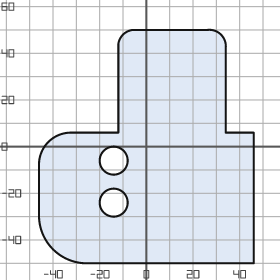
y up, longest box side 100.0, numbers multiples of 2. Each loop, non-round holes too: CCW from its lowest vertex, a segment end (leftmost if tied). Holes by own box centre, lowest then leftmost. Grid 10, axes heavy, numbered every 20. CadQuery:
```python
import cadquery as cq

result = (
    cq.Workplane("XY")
    .moveTo(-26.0, -50.0)
    .lineTo(46.0, -50.0)
    .lineTo(46.0, 6.0)
    .lineTo(34.0, 6.0)
    .lineTo(34.0, 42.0)
    .threePointArc((32.0, 48.0), (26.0, 50.0))
    .lineTo(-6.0, 50.0)
    .threePointArc((-10.0, 48.0), (-12.0, 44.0))
    .lineTo(-12.0, 6.0)
    .lineTo(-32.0, 6.0)
    .threePointArc((-42.0, 2.0), (-46.0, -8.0))
    .lineTo(-46.0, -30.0)
    .threePointArc((-40.0, -44.0), (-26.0, -50.0))
    .close()
    .moveTo(-14.0, -24.0)
    .circle(6.0)
    .moveTo(-14.0, -6.0)
    .circle(6.0)
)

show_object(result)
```